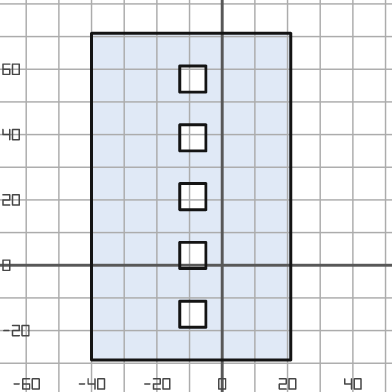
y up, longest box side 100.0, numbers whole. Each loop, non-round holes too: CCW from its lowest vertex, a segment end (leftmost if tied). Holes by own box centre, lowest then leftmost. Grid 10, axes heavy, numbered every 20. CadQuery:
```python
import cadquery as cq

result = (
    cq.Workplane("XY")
    .moveTo(-40.0, -29.0)
    .lineTo(21.0, -29.0)
    .lineTo(21.0, 71.0)
    .lineTo(-40.0, 71.0)
    .close()
    .moveTo(-13.0, -19.0)
    .lineTo(-5.0, -19.0)
    .lineTo(-5.0, -11.0)
    .lineTo(-13.0, -11.0)
    .close()
    .moveTo(-13.0, -1.0)
    .lineTo(-5.0, -1.0)
    .lineTo(-5.0, 7.0)
    .lineTo(-13.0, 7.0)
    .close()
    .moveTo(-13.0, 17.0)
    .lineTo(-5.0, 17.0)
    .lineTo(-5.0, 25.0)
    .lineTo(-13.0, 25.0)
    .close()
    .moveTo(-13.0, 35.0)
    .lineTo(-5.0, 35.0)
    .lineTo(-5.0, 43.0)
    .lineTo(-13.0, 43.0)
    .close()
    .moveTo(-13.0, 53.0)
    .lineTo(-5.0, 53.0)
    .lineTo(-5.0, 61.0)
    .lineTo(-13.0, 61.0)
    .close()
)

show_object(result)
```